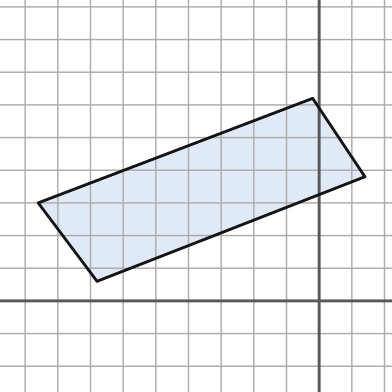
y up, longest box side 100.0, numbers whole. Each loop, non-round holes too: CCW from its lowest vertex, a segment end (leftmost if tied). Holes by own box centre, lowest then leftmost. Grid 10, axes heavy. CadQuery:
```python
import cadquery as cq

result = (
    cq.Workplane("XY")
    .moveTo(-68.0, 6.0)
    .lineTo(14.0, 38.0)
    .lineTo(-2.0, 62.0)
    .lineTo(-86.0, 30.0)
    .close()
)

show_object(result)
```